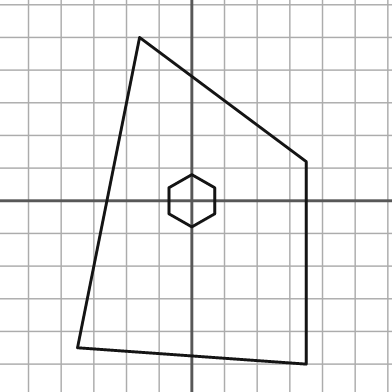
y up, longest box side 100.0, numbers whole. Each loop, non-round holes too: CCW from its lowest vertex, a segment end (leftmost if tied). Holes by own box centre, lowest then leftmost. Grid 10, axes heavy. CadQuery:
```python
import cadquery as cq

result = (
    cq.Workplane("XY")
    .moveTo(35.0, -50.0)
    .lineTo(35.0, 12.0)
    .lineTo(-16.0, 50.0)
    .lineTo(-35.0, -45.0)
    .close()
    .moveTo(0.0, -8.0)
    .lineTo(7.0, -4.0)
    .lineTo(7.0, 4.0)
    .lineTo(0.0, 8.0)
    .lineTo(-7.0, 4.0)
    .lineTo(-7.0, -4.0)
    .close()
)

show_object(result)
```